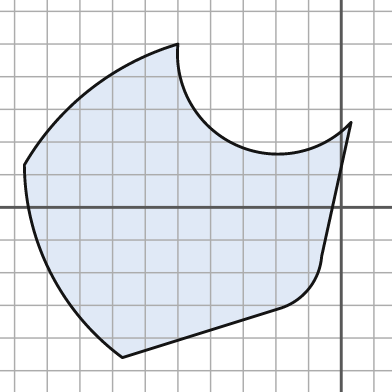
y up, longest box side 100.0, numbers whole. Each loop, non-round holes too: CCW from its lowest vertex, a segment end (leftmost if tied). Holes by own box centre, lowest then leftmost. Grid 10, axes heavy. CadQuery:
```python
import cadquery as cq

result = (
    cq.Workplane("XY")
    .moveTo(-67.0, -46.0)
    .lineTo(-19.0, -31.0)
    .threePointArc((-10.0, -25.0), (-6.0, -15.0))
    .lineTo(3.0, 26.0)
    .threePointArc((-32.0, 19.0), (-50.0, 50.0))
    .threePointArc((-77.0, 36.0), (-97.0, 13.0))
    .threePointArc((-89.0, -20.0), (-67.0, -46.0))
    .close()
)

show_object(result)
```